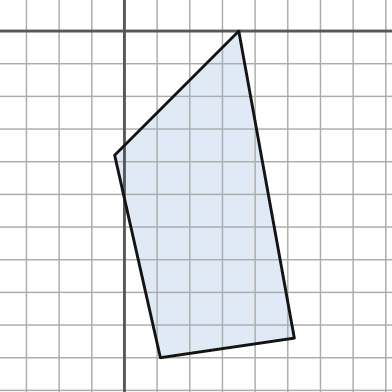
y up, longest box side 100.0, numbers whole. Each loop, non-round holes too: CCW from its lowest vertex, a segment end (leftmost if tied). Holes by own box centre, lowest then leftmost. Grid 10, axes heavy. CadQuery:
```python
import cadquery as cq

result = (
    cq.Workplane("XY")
    .moveTo(11.0, -100.0)
    .lineTo(52.0, -94.0)
    .lineTo(35.0, 0.0)
    .lineTo(-3.0, -38.0)
    .close()
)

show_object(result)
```